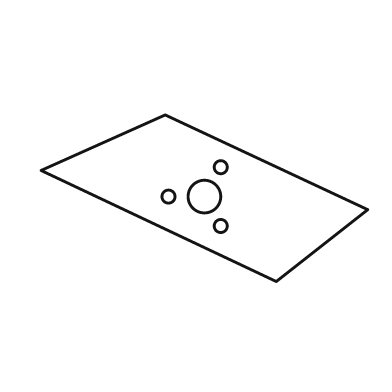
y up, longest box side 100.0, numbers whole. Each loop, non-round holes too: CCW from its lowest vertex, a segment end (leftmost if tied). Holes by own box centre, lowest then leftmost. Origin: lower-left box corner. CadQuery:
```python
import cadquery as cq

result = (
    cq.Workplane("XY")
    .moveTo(72.0, 0.0)
    .lineTo(100.0, 22.0)
    .lineTo(38.0, 51.0)
    .lineTo(0.0, 34.0)
    .close()
    .moveTo(55.0, 17.0)
    .circle(2.0)
    .moveTo(39.0, 26.0)
    .circle(2.0)
    .moveTo(50.0, 26.0)
    .circle(5.0)
    .moveTo(55.0, 35.0)
    .circle(2.0)
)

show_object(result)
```